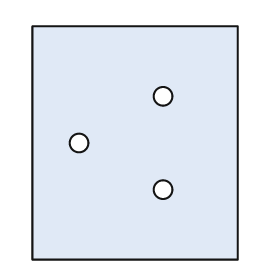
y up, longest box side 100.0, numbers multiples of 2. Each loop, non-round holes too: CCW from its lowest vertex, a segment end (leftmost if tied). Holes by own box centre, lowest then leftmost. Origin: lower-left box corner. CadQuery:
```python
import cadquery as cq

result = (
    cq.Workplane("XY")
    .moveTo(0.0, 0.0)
    .lineTo(88.0, 0.0)
    .lineTo(88.0, 100.0)
    .lineTo(0.0, 100.0)
    .close()
    .moveTo(56.0, 30.0)
    .circle(4.0)
    .moveTo(20.0, 50.0)
    .circle(4.0)
    .moveTo(56.0, 70.0)
    .circle(4.0)
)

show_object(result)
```